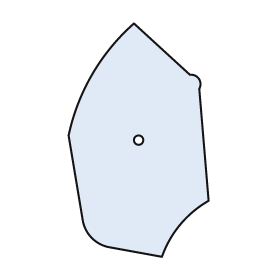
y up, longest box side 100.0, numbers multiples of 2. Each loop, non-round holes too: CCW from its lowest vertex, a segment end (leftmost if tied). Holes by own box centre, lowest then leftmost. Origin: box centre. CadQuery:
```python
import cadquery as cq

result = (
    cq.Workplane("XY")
    .moveTo(10.0, -50.0)
    .threePointArc((18.0, -36.0), (30.0, -26.0))
    .lineTo(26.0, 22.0)
    .threePointArc((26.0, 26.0), (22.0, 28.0))
    .lineTo(-2.0, 50.0)
    .threePointArc((-20.0, 28.0), (-30.0, 2.0))
    .lineTo(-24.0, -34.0)
    .threePointArc((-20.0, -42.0), (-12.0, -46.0))
    .close()
    .moveTo(0.0, 0.0)
    .circle(2.0)
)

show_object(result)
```